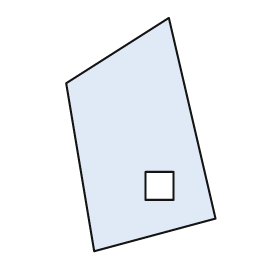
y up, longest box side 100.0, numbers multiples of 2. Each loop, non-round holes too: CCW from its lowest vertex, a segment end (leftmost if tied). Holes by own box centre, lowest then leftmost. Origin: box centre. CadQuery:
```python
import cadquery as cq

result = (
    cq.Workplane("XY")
    .moveTo(-20.0, -50.0)
    .lineTo(32.0, -36.0)
    .lineTo(12.0, 50.0)
    .lineTo(-32.0, 22.0)
    .close()
    .moveTo(2.0, -28.0)
    .lineTo(14.0, -28.0)
    .lineTo(14.0, -16.0)
    .lineTo(2.0, -16.0)
    .close()
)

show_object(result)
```